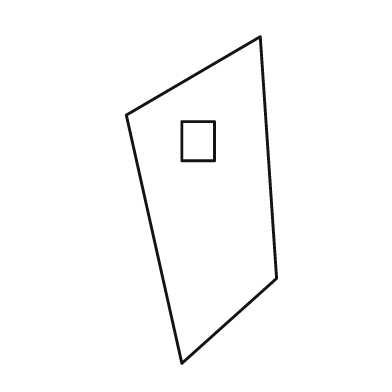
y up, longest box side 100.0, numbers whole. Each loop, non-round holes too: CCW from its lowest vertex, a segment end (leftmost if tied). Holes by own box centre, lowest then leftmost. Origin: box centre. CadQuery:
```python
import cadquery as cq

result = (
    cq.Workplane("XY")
    .moveTo(-6.0, -50.0)
    .lineTo(23.0, -24.0)
    .lineTo(18.0, 50.0)
    .lineTo(-23.0, 26.0)
    .close()
    .moveTo(-6.0, 12.0)
    .lineTo(4.0, 12.0)
    .lineTo(4.0, 24.0)
    .lineTo(-6.0, 24.0)
    .close()
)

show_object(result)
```